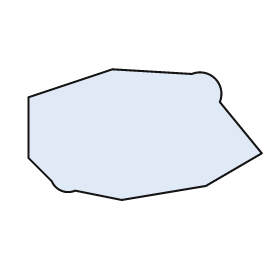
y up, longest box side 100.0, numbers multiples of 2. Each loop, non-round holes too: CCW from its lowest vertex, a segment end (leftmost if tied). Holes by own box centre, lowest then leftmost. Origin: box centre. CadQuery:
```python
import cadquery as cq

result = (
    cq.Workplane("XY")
    .moveTo(-10.0, -28.0)
    .lineTo(26.0, -22.0)
    .lineTo(50.0, -8.0)
    .lineTo(32.0, 14.0)
    .threePointArc((30.0, 24.0), (20.0, 26.0))
    .lineTo(-14.0, 28.0)
    .lineTo(-50.0, 16.0)
    .lineTo(-50.0, -10.0)
    .lineTo(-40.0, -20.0)
    .threePointArc((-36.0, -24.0), (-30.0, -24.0))
    .close()
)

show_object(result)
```